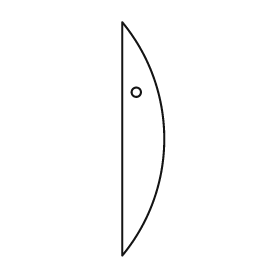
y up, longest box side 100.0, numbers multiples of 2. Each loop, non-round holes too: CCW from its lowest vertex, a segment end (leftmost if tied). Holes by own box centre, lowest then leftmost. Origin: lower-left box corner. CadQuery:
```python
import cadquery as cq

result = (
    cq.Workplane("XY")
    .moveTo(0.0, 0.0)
    .threePointArc((18.0, 50.0), (0.0, 100.0))
    .close()
    .moveTo(6.0, 70.0)
    .circle(2.0)
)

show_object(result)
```